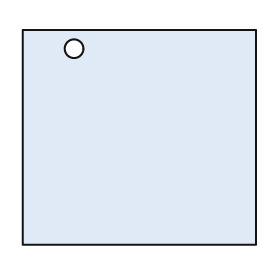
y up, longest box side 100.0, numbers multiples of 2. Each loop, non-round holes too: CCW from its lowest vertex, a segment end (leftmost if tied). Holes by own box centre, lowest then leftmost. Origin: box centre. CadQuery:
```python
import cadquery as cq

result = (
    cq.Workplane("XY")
    .moveTo(-50.0, -46.0)
    .lineTo(50.0, -46.0)
    .lineTo(50.0, 46.0)
    .lineTo(-50.0, 46.0)
    .close()
    .moveTo(-28.0, 38.0)
    .circle(4.0)
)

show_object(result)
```